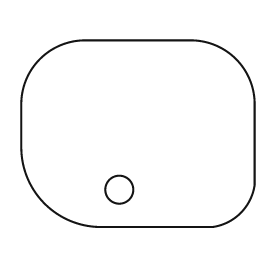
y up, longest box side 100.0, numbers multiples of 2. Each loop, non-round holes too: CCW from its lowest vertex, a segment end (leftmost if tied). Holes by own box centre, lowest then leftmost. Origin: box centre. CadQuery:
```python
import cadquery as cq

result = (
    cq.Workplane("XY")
    .moveTo(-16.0, -40.0)
    .lineTo(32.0, -40.0)
    .threePointArc((44.0, -34.0), (50.0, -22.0))
    .lineTo(50.0, 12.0)
    .threePointArc((42.0, 32.0), (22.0, 40.0))
    .lineTo(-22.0, 40.0)
    .threePointArc((-42.0, 32.0), (-50.0, 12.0))
    .lineTo(-50.0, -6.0)
    .threePointArc((-40.0, -30.0), (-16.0, -40.0))
    .close()
    .moveTo(-8.0, -24.0)
    .circle(6.0)
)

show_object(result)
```